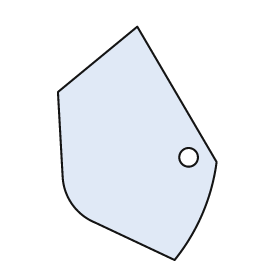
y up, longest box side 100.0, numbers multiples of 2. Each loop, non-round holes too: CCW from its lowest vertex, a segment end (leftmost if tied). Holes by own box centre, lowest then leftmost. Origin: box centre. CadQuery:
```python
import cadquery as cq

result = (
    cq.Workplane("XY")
    .moveTo(16.0, -50.0)
    .threePointArc((28.0, -30.0), (34.0, -8.0))
    .lineTo(0.0, 50.0)
    .lineTo(-34.0, 22.0)
    .lineTo(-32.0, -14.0)
    .threePointArc((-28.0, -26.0), (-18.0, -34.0))
    .close()
    .moveTo(22.0, -6.0)
    .circle(4.0)
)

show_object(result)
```